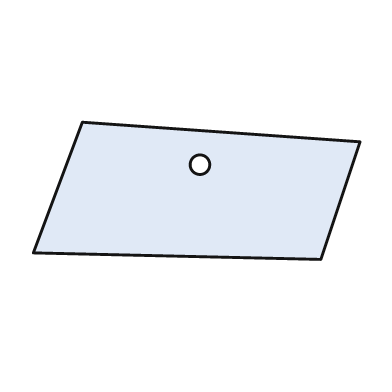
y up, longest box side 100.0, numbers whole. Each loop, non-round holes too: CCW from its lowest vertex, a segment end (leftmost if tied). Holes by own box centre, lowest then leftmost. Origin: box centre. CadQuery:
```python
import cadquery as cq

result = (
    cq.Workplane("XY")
    .moveTo(38.0, -21.0)
    .lineTo(50.0, 15.0)
    .lineTo(-35.0, 21.0)
    .lineTo(-50.0, -19.0)
    .close()
    .moveTo(1.0, 8.0)
    .circle(3.0)
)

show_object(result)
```